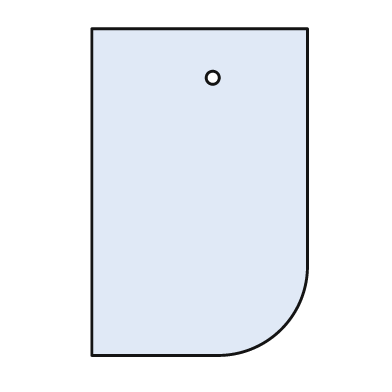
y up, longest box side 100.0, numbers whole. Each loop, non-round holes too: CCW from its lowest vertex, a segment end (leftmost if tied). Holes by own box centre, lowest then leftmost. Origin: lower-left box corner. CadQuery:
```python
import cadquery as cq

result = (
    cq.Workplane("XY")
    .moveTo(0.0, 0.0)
    .lineTo(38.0, 0.0)
    .threePointArc((58.0, 8.0), (66.0, 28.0))
    .lineTo(66.0, 100.0)
    .lineTo(0.0, 100.0)
    .close()
    .moveTo(37.0, 85.0)
    .circle(2.0)
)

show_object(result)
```